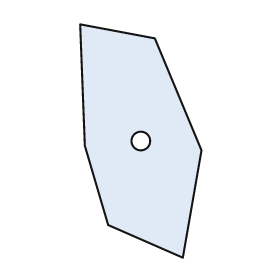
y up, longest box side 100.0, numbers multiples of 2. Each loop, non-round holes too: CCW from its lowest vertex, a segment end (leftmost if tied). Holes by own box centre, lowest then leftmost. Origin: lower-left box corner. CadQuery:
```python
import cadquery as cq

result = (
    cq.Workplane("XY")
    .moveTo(44.0, 0.0)
    .lineTo(52.0, 46.0)
    .lineTo(32.0, 94.0)
    .lineTo(0.0, 100.0)
    .lineTo(2.0, 48.0)
    .lineTo(12.0, 14.0)
    .close()
    .moveTo(26.0, 50.0)
    .circle(4.0)
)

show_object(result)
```